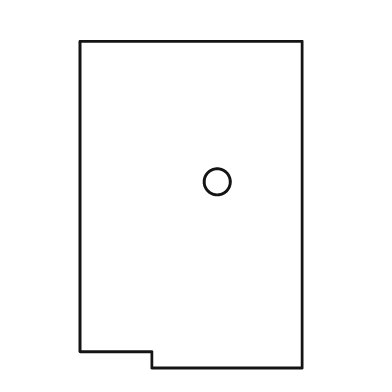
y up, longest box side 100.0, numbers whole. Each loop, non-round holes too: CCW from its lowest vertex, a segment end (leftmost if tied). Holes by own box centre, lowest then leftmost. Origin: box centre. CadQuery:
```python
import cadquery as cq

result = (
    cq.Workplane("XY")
    .moveTo(-12.0, -50.0)
    .lineTo(34.0, -50.0)
    .lineTo(34.0, 50.0)
    .lineTo(-34.0, 50.0)
    .lineTo(-34.0, -45.0)
    .lineTo(-12.0, -45.0)
    .close()
    .moveTo(8.0, 7.0)
    .circle(4.0)
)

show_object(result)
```